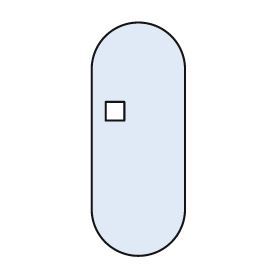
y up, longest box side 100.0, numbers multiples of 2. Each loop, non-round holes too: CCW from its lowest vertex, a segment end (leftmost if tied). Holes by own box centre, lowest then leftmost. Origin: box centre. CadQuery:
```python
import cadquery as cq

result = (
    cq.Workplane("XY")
    .moveTo(-20.0, -30.0)
    .threePointArc((0.0, -50.0), (20.0, -30.0))
    .lineTo(20.0, 30.0)
    .threePointArc((0.0, 50.0), (-20.0, 30.0))
    .close()
    .moveTo(-14.0, 8.0)
    .lineTo(-6.0, 8.0)
    .lineTo(-6.0, 16.0)
    .lineTo(-14.0, 16.0)
    .close()
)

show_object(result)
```